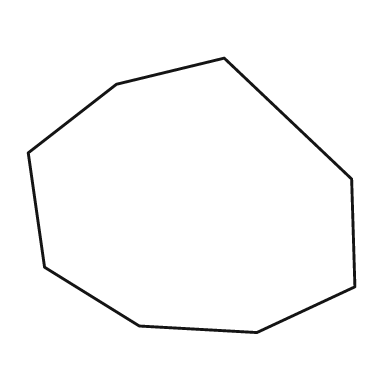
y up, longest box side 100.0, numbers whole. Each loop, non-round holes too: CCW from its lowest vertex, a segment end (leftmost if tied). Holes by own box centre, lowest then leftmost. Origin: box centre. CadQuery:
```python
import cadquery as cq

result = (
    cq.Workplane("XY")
    .moveTo(20.0, -42.0)
    .lineTo(50.0, -28.0)
    .lineTo(49.0, 5.0)
    .lineTo(10.0, 42.0)
    .lineTo(-23.0, 34.0)
    .lineTo(-50.0, 13.0)
    .lineTo(-45.0, -22.0)
    .lineTo(-16.0, -40.0)
    .close()
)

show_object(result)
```